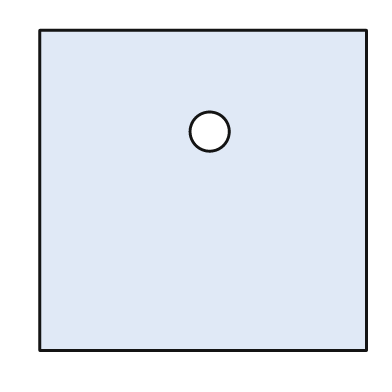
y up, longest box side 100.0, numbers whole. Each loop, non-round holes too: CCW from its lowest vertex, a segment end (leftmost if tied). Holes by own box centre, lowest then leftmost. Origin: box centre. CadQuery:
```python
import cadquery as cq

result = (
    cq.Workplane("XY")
    .moveTo(-50.0, -49.0)
    .lineTo(50.0, -49.0)
    .lineTo(50.0, 49.0)
    .lineTo(-50.0, 49.0)
    .close()
    .moveTo(2.0, 18.0)
    .circle(6.0)
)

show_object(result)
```